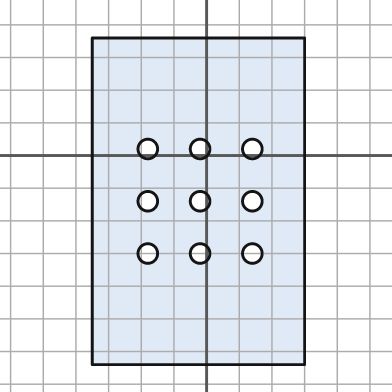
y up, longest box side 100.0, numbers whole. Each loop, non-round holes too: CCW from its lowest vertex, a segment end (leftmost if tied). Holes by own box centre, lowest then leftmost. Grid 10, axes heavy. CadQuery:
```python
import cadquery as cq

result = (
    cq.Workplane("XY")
    .moveTo(-35.0, -64.0)
    .lineTo(30.0, -64.0)
    .lineTo(30.0, 36.0)
    .lineTo(-35.0, 36.0)
    .close()
    .moveTo(-18.0, -30.0)
    .circle(3.0)
    .moveTo(-2.0, -30.0)
    .circle(3.0)
    .moveTo(14.0, -30.0)
    .circle(3.0)
    .moveTo(-18.0, -14.0)
    .circle(3.0)
    .moveTo(-2.0, -14.0)
    .circle(3.0)
    .moveTo(14.0, -14.0)
    .circle(3.0)
    .moveTo(-18.0, 2.0)
    .circle(3.0)
    .moveTo(-2.0, 2.0)
    .circle(3.0)
    .moveTo(14.0, 2.0)
    .circle(3.0)
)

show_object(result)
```